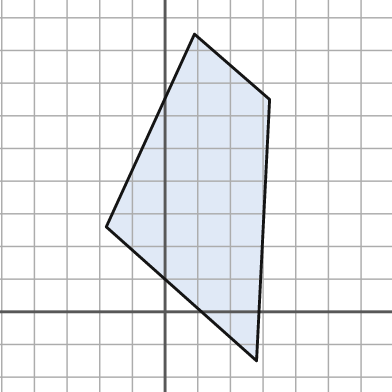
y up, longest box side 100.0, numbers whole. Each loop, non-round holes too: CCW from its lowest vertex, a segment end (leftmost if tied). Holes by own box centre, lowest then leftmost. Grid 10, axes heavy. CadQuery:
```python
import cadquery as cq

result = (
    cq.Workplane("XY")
    .moveTo(28.0, -15.0)
    .lineTo(32.0, 65.0)
    .lineTo(9.0, 85.0)
    .lineTo(-18.0, 26.0)
    .close()
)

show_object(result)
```